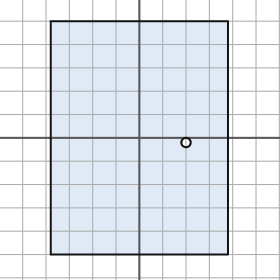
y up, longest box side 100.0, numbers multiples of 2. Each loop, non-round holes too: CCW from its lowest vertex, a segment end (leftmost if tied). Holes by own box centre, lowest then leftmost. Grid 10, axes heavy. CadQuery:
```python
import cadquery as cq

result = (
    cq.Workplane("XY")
    .moveTo(-38.0, -50.0)
    .lineTo(38.0, -50.0)
    .lineTo(38.0, 50.0)
    .lineTo(-38.0, 50.0)
    .close()
    .moveTo(20.0, -2.0)
    .circle(2.0)
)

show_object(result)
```